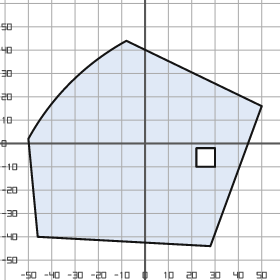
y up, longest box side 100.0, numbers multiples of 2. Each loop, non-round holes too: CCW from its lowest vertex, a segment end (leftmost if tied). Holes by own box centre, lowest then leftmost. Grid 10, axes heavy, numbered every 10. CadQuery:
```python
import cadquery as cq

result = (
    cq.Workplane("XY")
    .moveTo(28.0, -44.0)
    .lineTo(50.0, 16.0)
    .lineTo(-8.0, 44.0)
    .threePointArc((-32.0, 26.0), (-50.0, 2.0))
    .lineTo(-46.0, -40.0)
    .close()
    .moveTo(22.0, -10.0)
    .lineTo(30.0, -10.0)
    .lineTo(30.0, -2.0)
    .lineTo(22.0, -2.0)
    .close()
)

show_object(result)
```